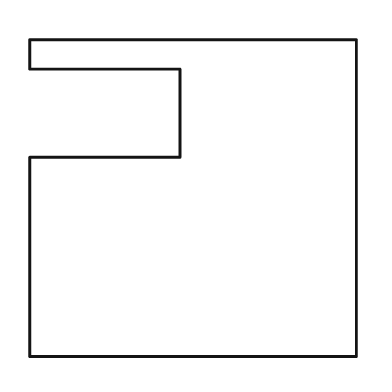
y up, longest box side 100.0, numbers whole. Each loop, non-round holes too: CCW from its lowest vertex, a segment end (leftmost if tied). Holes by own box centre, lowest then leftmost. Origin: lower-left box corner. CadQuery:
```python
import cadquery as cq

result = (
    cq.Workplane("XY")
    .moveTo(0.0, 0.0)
    .lineTo(100.0, 0.0)
    .lineTo(100.0, 97.0)
    .lineTo(0.0, 97.0)
    .lineTo(0.0, 88.0)
    .lineTo(46.0, 88.0)
    .lineTo(46.0, 61.0)
    .lineTo(0.0, 61.0)
    .close()
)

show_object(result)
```